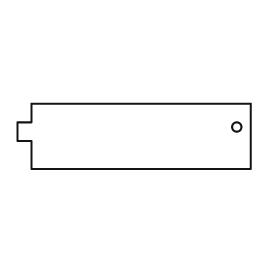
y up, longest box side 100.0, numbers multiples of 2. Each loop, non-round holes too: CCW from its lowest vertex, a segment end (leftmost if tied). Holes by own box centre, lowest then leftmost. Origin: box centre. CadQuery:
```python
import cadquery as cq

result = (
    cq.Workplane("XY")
    .moveTo(-44.0, -14.0)
    .lineTo(50.0, -14.0)
    .lineTo(50.0, 14.0)
    .lineTo(-44.0, 14.0)
    .lineTo(-44.0, 6.0)
    .lineTo(-50.0, 6.0)
    .lineTo(-50.0, -2.0)
    .lineTo(-44.0, -2.0)
    .close()
    .moveTo(44.0, 4.0)
    .circle(2.0)
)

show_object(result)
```